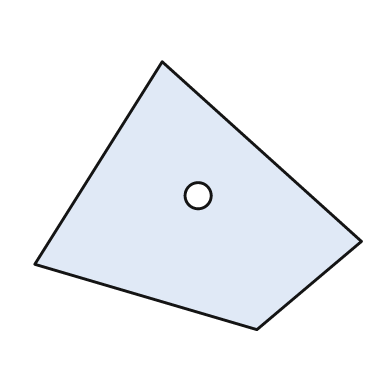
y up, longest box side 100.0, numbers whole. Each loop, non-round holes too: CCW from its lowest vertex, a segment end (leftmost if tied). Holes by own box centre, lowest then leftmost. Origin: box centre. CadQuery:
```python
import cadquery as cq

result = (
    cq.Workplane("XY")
    .moveTo(18.0, -41.0)
    .lineTo(50.0, -14.0)
    .lineTo(-11.0, 41.0)
    .lineTo(-50.0, -21.0)
    .close()
    .moveTo(0.0, 0.0)
    .circle(4.0)
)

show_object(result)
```